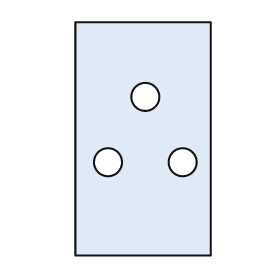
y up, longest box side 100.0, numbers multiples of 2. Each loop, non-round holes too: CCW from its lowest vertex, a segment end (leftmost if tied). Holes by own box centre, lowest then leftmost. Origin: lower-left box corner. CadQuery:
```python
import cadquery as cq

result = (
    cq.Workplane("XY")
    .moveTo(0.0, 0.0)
    .lineTo(58.0, 0.0)
    .lineTo(58.0, 100.0)
    .lineTo(0.0, 100.0)
    .close()
    .moveTo(14.0, 40.0)
    .circle(6.0)
    .moveTo(46.0, 40.0)
    .circle(6.0)
    .moveTo(30.0, 68.0)
    .circle(6.0)
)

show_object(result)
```